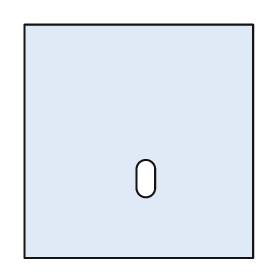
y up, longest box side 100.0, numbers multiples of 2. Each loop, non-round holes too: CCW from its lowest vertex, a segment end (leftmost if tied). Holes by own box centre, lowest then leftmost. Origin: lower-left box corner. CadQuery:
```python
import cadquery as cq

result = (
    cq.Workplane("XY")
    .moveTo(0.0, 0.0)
    .lineTo(98.0, 0.0)
    .lineTo(98.0, 100.0)
    .lineTo(0.0, 100.0)
    .close()
    .moveTo(48.0, 30.0)
    .threePointArc((52.0, 26.0), (56.0, 30.0))
    .lineTo(56.0, 38.0)
    .threePointArc((52.0, 42.0), (48.0, 38.0))
    .close()
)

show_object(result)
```